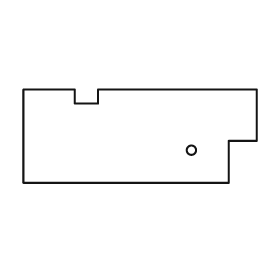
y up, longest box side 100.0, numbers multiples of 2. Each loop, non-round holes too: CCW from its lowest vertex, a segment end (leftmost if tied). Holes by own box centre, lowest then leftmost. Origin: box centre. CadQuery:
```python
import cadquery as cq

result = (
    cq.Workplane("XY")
    .moveTo(-50.0, -20.0)
    .lineTo(38.0, -20.0)
    .lineTo(38.0, -2.0)
    .lineTo(50.0, -2.0)
    .lineTo(50.0, 20.0)
    .lineTo(-18.0, 20.0)
    .lineTo(-18.0, 14.0)
    .lineTo(-28.0, 14.0)
    .lineTo(-28.0, 20.0)
    .lineTo(-50.0, 20.0)
    .close()
    .moveTo(22.0, -6.0)
    .circle(2.0)
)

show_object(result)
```